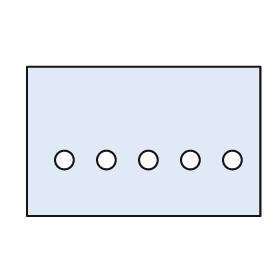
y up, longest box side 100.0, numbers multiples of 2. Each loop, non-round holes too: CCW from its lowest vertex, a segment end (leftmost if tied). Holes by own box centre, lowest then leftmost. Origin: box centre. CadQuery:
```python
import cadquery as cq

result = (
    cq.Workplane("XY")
    .moveTo(-50.0, -32.0)
    .lineTo(50.0, -32.0)
    .lineTo(50.0, 32.0)
    .lineTo(-50.0, 32.0)
    .close()
    .moveTo(-34.0, -8.0)
    .circle(4.0)
    .moveTo(-16.0, -8.0)
    .circle(4.0)
    .moveTo(2.0, -8.0)
    .circle(4.0)
    .moveTo(20.0, -8.0)
    .circle(4.0)
    .moveTo(38.0, -8.0)
    .circle(4.0)
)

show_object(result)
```